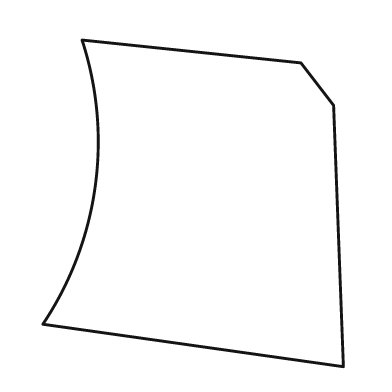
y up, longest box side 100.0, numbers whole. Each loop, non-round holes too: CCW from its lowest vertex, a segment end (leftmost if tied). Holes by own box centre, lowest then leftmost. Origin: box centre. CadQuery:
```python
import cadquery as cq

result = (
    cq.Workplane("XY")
    .moveTo(46.0, -50.0)
    .lineTo(43.0, 30.0)
    .lineTo(33.0, 43.0)
    .lineTo(-34.0, 50.0)
    .threePointArc((-30.0, 5.0), (-46.0, -37.0))
    .close()
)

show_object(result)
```